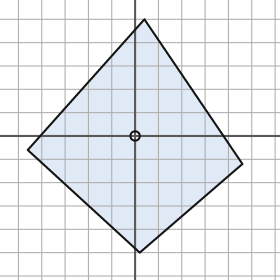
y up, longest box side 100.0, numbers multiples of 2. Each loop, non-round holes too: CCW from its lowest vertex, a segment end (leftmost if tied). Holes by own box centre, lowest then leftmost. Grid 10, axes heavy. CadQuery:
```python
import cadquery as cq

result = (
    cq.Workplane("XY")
    .moveTo(2.0, -50.0)
    .lineTo(46.0, -12.0)
    .lineTo(4.0, 50.0)
    .lineTo(-46.0, -6.0)
    .close()
    .moveTo(0.0, 0.0)
    .circle(2.0)
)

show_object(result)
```